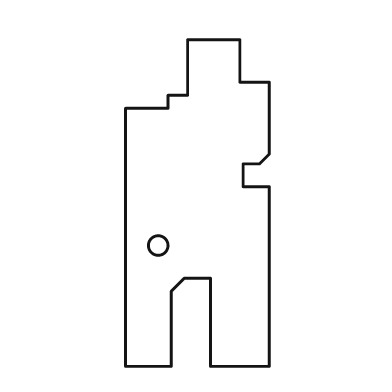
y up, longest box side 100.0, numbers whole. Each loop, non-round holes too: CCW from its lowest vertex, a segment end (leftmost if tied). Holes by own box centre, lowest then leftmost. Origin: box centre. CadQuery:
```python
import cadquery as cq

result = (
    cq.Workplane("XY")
    .moveTo(-22.0, -50.0)
    .lineTo(-8.0, -50.0)
    .lineTo(-8.0, -27.0)
    .lineTo(-4.0, -23.0)
    .lineTo(4.0, -23.0)
    .lineTo(4.0, -50.0)
    .lineTo(22.0, -50.0)
    .lineTo(22.0, 5.0)
    .lineTo(14.0, 5.0)
    .lineTo(14.0, 12.0)
    .lineTo(19.0, 12.0)
    .lineTo(22.0, 15.0)
    .lineTo(22.0, 37.0)
    .lineTo(13.0, 37.0)
    .lineTo(13.0, 50.0)
    .lineTo(-3.0, 50.0)
    .lineTo(-3.0, 33.0)
    .lineTo(-9.0, 33.0)
    .lineTo(-9.0, 29.0)
    .lineTo(-22.0, 29.0)
    .close()
    .moveTo(-12.0, -13.0)
    .circle(3.0)
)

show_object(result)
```